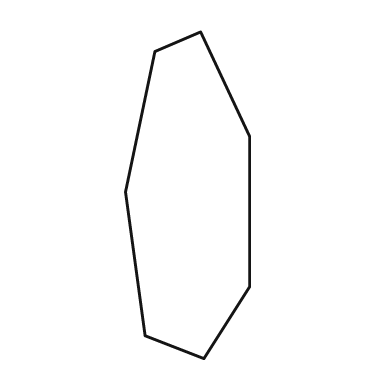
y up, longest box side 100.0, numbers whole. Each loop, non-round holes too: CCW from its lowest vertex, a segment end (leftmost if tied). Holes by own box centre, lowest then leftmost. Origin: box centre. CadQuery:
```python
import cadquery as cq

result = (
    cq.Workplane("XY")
    .moveTo(5.0, -50.0)
    .lineTo(19.0, -28.0)
    .lineTo(19.0, 18.0)
    .lineTo(4.0, 50.0)
    .lineTo(-10.0, 44.0)
    .lineTo(-19.0, 1.0)
    .lineTo(-13.0, -43.0)
    .close()
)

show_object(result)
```